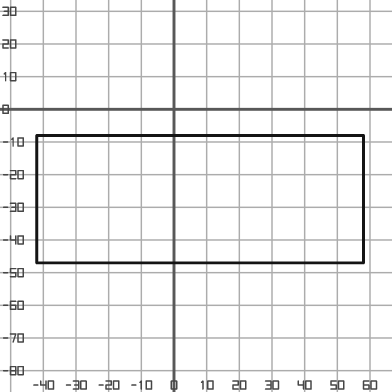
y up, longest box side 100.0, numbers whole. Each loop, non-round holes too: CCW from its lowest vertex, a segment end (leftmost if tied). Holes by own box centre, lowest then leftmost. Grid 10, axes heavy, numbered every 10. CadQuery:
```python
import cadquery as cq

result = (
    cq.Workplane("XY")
    .moveTo(-42.0, -47.0)
    .lineTo(58.0, -47.0)
    .lineTo(58.0, -8.0)
    .lineTo(-42.0, -8.0)
    .close()
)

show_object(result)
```